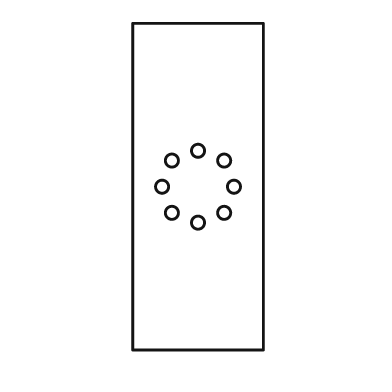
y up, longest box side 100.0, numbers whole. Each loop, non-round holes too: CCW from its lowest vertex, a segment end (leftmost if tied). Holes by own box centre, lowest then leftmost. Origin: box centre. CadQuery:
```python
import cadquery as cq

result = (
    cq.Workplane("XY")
    .moveTo(-20.0, -50.0)
    .lineTo(20.0, -50.0)
    .lineTo(20.0, 50.0)
    .lineTo(-20.0, 50.0)
    .close()
    .moveTo(0.0, -11.0)
    .circle(2.0)
    .moveTo(-8.0, -8.0)
    .circle(2.0)
    .moveTo(8.0, -8.0)
    .circle(2.0)
    .moveTo(-11.0, 0.0)
    .circle(2.0)
    .moveTo(11.0, 0.0)
    .circle(2.0)
    .moveTo(-8.0, 8.0)
    .circle(2.0)
    .moveTo(8.0, 8.0)
    .circle(2.0)
    .moveTo(0.0, 11.0)
    .circle(2.0)
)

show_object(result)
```